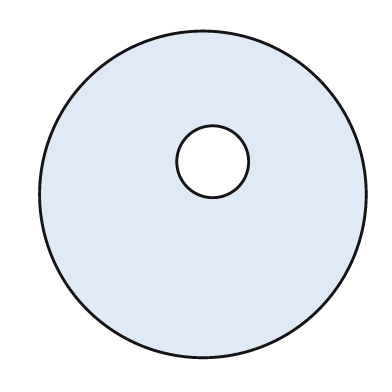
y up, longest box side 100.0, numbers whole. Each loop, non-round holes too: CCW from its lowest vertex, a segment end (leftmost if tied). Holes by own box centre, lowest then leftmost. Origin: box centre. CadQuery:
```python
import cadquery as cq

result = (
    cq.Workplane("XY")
    .moveTo(0.0, 0.0)
    .circle(50.0)
    .moveTo(3.0, 10.0)
    .circle(11.0)
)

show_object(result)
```